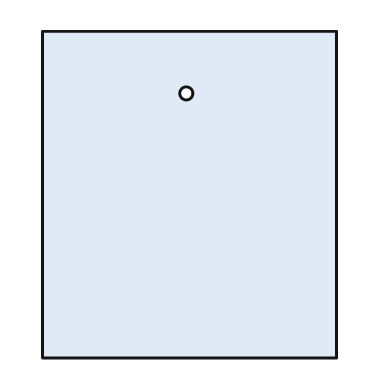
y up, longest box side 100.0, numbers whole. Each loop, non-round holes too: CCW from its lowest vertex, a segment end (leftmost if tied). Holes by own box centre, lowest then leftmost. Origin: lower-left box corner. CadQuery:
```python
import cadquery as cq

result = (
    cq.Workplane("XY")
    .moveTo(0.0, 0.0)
    .lineTo(90.0, 0.0)
    .lineTo(90.0, 100.0)
    .lineTo(0.0, 100.0)
    .close()
    .moveTo(44.0, 81.0)
    .circle(2.0)
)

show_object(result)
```